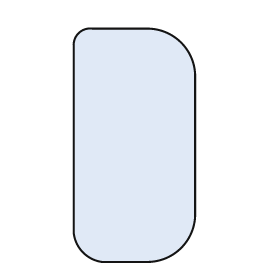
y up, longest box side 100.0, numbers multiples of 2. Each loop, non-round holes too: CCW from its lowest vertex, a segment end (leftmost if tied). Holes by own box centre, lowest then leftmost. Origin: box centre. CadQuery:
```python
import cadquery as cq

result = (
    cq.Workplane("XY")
    .moveTo(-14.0, -50.0)
    .lineTo(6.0, -50.0)
    .threePointArc((20.0, -44.0), (26.0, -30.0))
    .lineTo(26.0, 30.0)
    .threePointArc((20.0, 44.0), (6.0, 50.0))
    .lineTo(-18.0, 50.0)
    .threePointArc((-24.0, 48.0), (-26.0, 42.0))
    .lineTo(-26.0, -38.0)
    .threePointArc((-22.0, -46.0), (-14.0, -50.0))
    .close()
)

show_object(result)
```